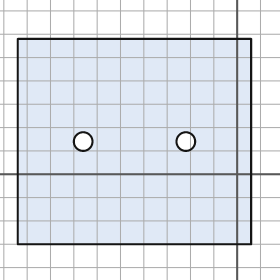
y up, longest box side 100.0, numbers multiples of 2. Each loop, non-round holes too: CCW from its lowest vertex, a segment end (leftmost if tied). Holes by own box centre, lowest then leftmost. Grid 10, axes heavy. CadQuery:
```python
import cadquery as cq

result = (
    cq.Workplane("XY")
    .moveTo(-94.0, -30.0)
    .lineTo(6.0, -30.0)
    .lineTo(6.0, 58.0)
    .lineTo(-94.0, 58.0)
    .close()
    .moveTo(-66.0, 14.0)
    .circle(4.0)
    .moveTo(-22.0, 14.0)
    .circle(4.0)
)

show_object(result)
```